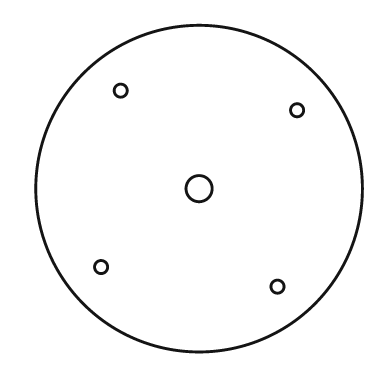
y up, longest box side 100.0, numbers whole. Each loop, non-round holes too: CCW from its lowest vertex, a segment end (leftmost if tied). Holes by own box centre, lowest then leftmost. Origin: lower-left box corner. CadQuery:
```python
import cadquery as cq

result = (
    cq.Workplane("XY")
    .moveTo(50.0, 50.0)
    .circle(50.0)
    .moveTo(74.0, 20.0)
    .circle(2.0)
    .moveTo(20.0, 26.0)
    .circle(2.0)
    .moveTo(50.0, 50.0)
    .circle(4.0)
    .moveTo(80.0, 74.0)
    .circle(2.0)
    .moveTo(26.0, 80.0)
    .circle(2.0)
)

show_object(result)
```